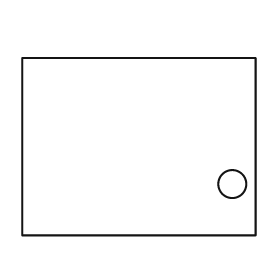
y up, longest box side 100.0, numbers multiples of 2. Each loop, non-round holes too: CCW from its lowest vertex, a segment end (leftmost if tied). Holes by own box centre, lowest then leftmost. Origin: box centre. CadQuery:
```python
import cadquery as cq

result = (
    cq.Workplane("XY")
    .moveTo(-50.0, -38.0)
    .lineTo(50.0, -38.0)
    .lineTo(50.0, 38.0)
    .lineTo(-50.0, 38.0)
    .close()
    .moveTo(40.0, -16.0)
    .circle(6.0)
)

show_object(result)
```